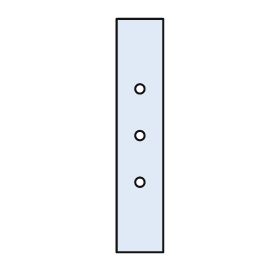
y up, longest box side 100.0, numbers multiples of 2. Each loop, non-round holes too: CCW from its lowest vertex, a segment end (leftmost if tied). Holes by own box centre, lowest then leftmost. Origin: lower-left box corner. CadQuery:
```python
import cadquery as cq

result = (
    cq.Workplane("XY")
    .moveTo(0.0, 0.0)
    .lineTo(20.0, 0.0)
    .lineTo(20.0, 100.0)
    .lineTo(0.0, 100.0)
    .close()
    .moveTo(10.0, 30.0)
    .circle(2.0)
    .moveTo(10.0, 50.0)
    .circle(2.0)
    .moveTo(10.0, 70.0)
    .circle(2.0)
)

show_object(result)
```